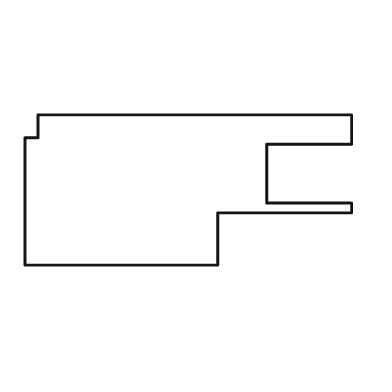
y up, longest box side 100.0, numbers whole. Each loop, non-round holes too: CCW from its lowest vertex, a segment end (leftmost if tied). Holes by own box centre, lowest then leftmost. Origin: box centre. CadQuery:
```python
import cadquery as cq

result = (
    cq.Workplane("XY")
    .moveTo(-50.0, -23.0)
    .lineTo(9.0, -23.0)
    .lineTo(9.0, -7.0)
    .lineTo(50.0, -7.0)
    .lineTo(50.0, -4.0)
    .lineTo(24.0, -4.0)
    .lineTo(24.0, 14.0)
    .lineTo(50.0, 14.0)
    .lineTo(50.0, 23.0)
    .lineTo(-46.0, 23.0)
    .lineTo(-46.0, 16.0)
    .lineTo(-50.0, 16.0)
    .close()
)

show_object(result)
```